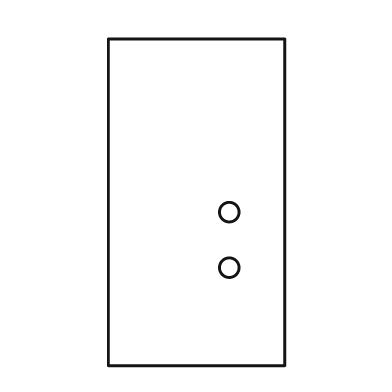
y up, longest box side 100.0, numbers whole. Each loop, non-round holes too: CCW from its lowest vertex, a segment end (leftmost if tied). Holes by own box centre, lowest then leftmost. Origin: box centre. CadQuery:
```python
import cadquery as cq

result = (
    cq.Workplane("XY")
    .moveTo(-27.0, -50.0)
    .lineTo(27.0, -50.0)
    .lineTo(27.0, 50.0)
    .lineTo(-27.0, 50.0)
    .close()
    .moveTo(10.0, -20.0)
    .circle(3.0)
    .moveTo(10.0, -3.0)
    .circle(3.0)
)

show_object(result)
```